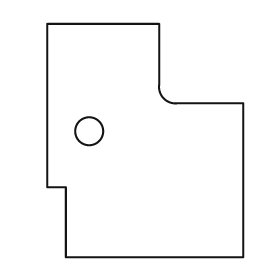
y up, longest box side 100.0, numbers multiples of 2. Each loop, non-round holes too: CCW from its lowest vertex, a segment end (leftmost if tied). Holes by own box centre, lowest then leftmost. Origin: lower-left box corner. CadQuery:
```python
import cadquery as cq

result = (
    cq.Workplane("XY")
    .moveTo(8.0, 0.0)
    .lineTo(84.0, 0.0)
    .lineTo(84.0, 66.0)
    .lineTo(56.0, 66.0)
    .threePointArc((50.0, 68.0), (48.0, 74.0))
    .lineTo(48.0, 100.0)
    .lineTo(0.0, 100.0)
    .lineTo(0.0, 30.0)
    .lineTo(8.0, 30.0)
    .close()
    .moveTo(18.0, 54.0)
    .circle(6.0)
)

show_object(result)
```